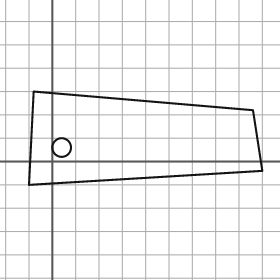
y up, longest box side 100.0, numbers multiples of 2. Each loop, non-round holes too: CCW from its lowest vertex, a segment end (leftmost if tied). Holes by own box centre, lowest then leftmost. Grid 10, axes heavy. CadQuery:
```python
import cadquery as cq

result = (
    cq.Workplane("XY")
    .moveTo(-10.0, -10.0)
    .lineTo(90.0, -4.0)
    .lineTo(86.0, 22.0)
    .lineTo(-8.0, 30.0)
    .close()
    .moveTo(4.0, 6.0)
    .circle(4.0)
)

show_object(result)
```